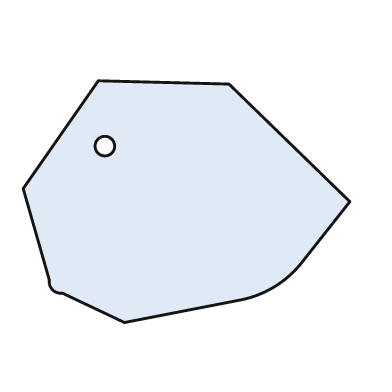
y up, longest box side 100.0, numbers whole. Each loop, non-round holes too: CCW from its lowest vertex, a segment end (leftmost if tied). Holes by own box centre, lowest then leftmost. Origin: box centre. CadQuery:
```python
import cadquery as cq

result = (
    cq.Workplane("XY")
    .moveTo(-19.0, -37.0)
    .lineTo(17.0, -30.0)
    .threePointArc((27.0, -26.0), (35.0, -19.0))
    .lineTo(50.0, 0.0)
    .lineTo(13.0, 36.0)
    .lineTo(-27.0, 37.0)
    .lineTo(-50.0, 4.0)
    .lineTo(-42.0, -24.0)
    .threePointArc((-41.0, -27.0), (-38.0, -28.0))
    .close()
    .moveTo(-25.0, 17.0)
    .circle(3.0)
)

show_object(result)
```